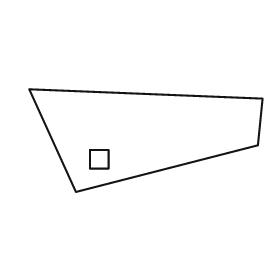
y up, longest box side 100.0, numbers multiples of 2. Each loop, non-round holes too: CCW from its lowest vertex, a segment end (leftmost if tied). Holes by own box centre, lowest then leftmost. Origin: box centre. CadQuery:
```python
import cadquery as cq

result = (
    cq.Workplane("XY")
    .moveTo(-30.0, -22.0)
    .lineTo(48.0, -2.0)
    .lineTo(50.0, 18.0)
    .lineTo(-50.0, 22.0)
    .close()
    .moveTo(-24.0, -12.0)
    .lineTo(-16.0, -12.0)
    .lineTo(-16.0, -4.0)
    .lineTo(-24.0, -4.0)
    .close()
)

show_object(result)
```